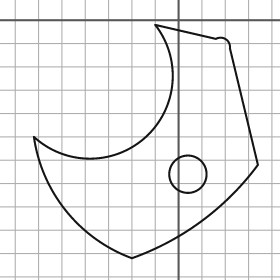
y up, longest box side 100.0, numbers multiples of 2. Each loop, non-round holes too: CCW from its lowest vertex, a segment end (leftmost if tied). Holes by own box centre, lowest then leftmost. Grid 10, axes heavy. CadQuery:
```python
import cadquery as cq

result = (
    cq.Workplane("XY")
    .moveTo(-20.0, -102.0)
    .threePointArc((10.0, -86.0), (34.0, -62.0))
    .lineTo(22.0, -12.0)
    .threePointArc((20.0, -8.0), (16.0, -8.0))
    .lineTo(-10.0, -2.0)
    .threePointArc((-14.0, -50.0), (-62.0, -50.0))
    .threePointArc((-48.0, -82.0), (-20.0, -102.0))
    .close()
    .moveTo(4.0, -66.0)
    .circle(8.0)
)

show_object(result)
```